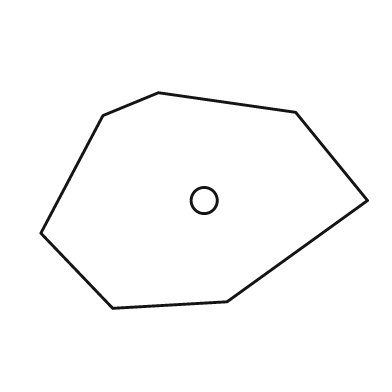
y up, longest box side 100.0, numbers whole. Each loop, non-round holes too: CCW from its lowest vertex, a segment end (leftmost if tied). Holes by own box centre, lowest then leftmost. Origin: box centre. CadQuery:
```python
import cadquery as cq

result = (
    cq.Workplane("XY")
    .moveTo(-28.0, -33.0)
    .lineTo(7.0, -31.0)
    .lineTo(50.0, 0.0)
    .lineTo(28.0, 27.0)
    .lineTo(-14.0, 33.0)
    .lineTo(-31.0, 26.0)
    .lineTo(-50.0, -10.0)
    .close()
    .moveTo(0.0, 0.0)
    .circle(4.0)
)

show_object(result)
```